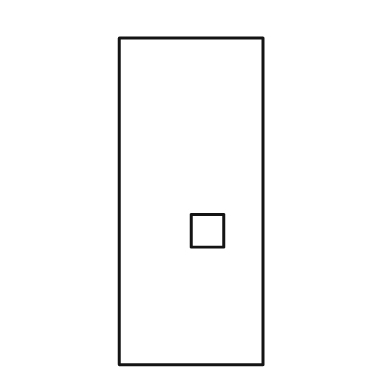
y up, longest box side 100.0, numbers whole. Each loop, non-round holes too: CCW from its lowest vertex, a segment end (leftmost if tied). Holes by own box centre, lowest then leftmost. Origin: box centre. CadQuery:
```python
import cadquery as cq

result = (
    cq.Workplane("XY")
    .moveTo(-22.0, -50.0)
    .lineTo(22.0, -50.0)
    .lineTo(22.0, 50.0)
    .lineTo(-22.0, 50.0)
    .close()
    .moveTo(0.0, -14.0)
    .lineTo(10.0, -14.0)
    .lineTo(10.0, -4.0)
    .lineTo(0.0, -4.0)
    .close()
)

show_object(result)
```